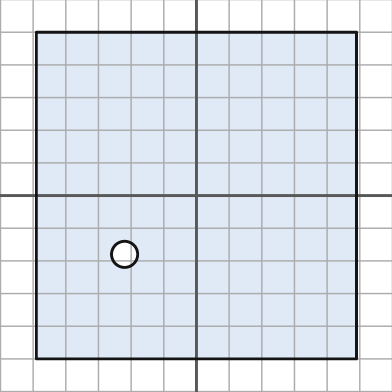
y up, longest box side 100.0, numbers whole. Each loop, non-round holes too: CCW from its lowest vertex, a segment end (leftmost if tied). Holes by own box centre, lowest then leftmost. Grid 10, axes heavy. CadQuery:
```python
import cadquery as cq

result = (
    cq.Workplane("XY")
    .moveTo(-49.0, -50.0)
    .lineTo(49.0, -50.0)
    .lineTo(49.0, 50.0)
    .lineTo(-49.0, 50.0)
    .close()
    .moveTo(-22.0, -18.0)
    .circle(4.0)
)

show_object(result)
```